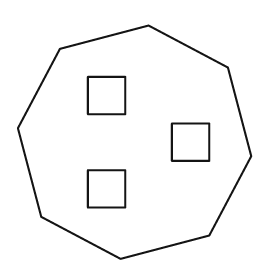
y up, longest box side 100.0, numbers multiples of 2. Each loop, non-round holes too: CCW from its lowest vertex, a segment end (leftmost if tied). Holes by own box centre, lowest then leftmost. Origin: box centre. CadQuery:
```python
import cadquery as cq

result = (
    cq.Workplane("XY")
    .moveTo(-6.0, -50.0)
    .lineTo(32.0, -40.0)
    .lineTo(50.0, -6.0)
    .lineTo(40.0, 32.0)
    .lineTo(6.0, 50.0)
    .lineTo(-32.0, 40.0)
    .lineTo(-50.0, 6.0)
    .lineTo(-40.0, -32.0)
    .close()
    .moveTo(-20.0, -28.0)
    .lineTo(-4.0, -28.0)
    .lineTo(-4.0, -12.0)
    .lineTo(-20.0, -12.0)
    .close()
    .moveTo(16.0, -8.0)
    .lineTo(32.0, -8.0)
    .lineTo(32.0, 8.0)
    .lineTo(16.0, 8.0)
    .close()
    .moveTo(-20.0, 12.0)
    .lineTo(-4.0, 12.0)
    .lineTo(-4.0, 28.0)
    .lineTo(-20.0, 28.0)
    .close()
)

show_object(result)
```